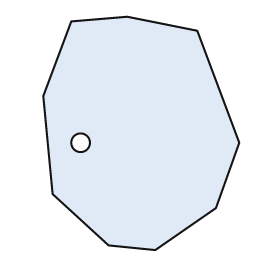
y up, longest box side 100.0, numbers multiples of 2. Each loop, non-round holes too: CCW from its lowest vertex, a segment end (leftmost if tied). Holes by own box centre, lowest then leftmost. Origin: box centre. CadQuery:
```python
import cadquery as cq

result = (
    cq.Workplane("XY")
    .moveTo(6.0, -50.0)
    .lineTo(32.0, -32.0)
    .lineTo(42.0, -4.0)
    .lineTo(24.0, 44.0)
    .lineTo(-6.0, 50.0)
    .lineTo(-30.0, 48.0)
    .lineTo(-42.0, 16.0)
    .lineTo(-38.0, -26.0)
    .lineTo(-14.0, -48.0)
    .close()
    .moveTo(-26.0, -4.0)
    .circle(4.0)
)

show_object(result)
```